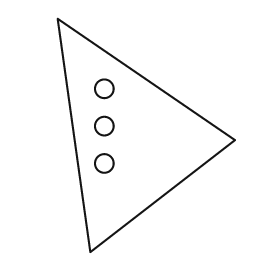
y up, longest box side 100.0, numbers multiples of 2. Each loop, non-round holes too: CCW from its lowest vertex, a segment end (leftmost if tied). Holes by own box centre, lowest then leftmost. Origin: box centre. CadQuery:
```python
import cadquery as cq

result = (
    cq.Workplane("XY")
    .moveTo(-24.0, -50.0)
    .lineTo(38.0, -2.0)
    .lineTo(-38.0, 50.0)
    .close()
    .moveTo(-18.0, -12.0)
    .circle(4.0)
    .moveTo(-18.0, 4.0)
    .circle(4.0)
    .moveTo(-18.0, 20.0)
    .circle(4.0)
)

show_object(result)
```